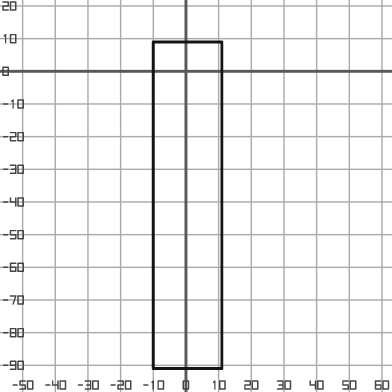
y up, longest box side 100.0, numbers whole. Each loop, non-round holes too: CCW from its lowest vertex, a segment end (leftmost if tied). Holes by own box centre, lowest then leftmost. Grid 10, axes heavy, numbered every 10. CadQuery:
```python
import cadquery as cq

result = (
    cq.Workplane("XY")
    .moveTo(-10.0, -91.0)
    .lineTo(11.0, -91.0)
    .lineTo(11.0, 9.0)
    .lineTo(-10.0, 9.0)
    .close()
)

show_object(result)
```